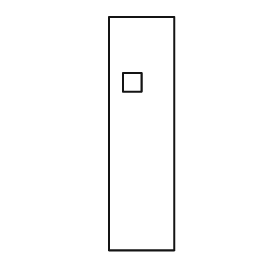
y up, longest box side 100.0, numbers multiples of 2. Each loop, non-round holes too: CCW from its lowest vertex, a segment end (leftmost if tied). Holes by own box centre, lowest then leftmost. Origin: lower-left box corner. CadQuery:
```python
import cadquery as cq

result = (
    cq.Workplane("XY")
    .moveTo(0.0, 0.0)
    .lineTo(28.0, 0.0)
    .lineTo(28.0, 100.0)
    .lineTo(0.0, 100.0)
    .close()
    .moveTo(6.0, 68.0)
    .lineTo(14.0, 68.0)
    .lineTo(14.0, 76.0)
    .lineTo(6.0, 76.0)
    .close()
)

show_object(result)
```